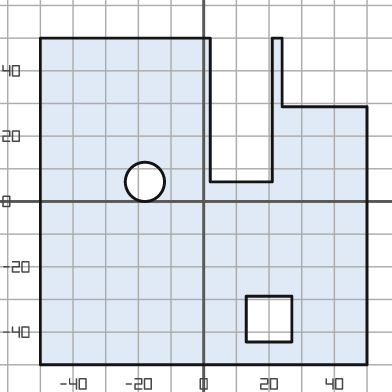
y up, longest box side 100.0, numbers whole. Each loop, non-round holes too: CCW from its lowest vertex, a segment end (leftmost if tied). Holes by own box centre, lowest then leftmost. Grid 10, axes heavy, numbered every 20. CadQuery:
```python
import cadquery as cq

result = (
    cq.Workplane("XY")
    .moveTo(-50.0, -50.0)
    .lineTo(50.0, -50.0)
    .lineTo(50.0, 29.0)
    .lineTo(24.0, 29.0)
    .lineTo(24.0, 50.0)
    .lineTo(21.0, 50.0)
    .lineTo(21.0, 6.0)
    .lineTo(2.0, 6.0)
    .lineTo(2.0, 50.0)
    .lineTo(-50.0, 50.0)
    .close()
    .moveTo(13.0, -43.0)
    .lineTo(27.0, -43.0)
    .lineTo(27.0, -29.0)
    .lineTo(13.0, -29.0)
    .close()
    .moveTo(-18.0, 6.0)
    .circle(6.0)
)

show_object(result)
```